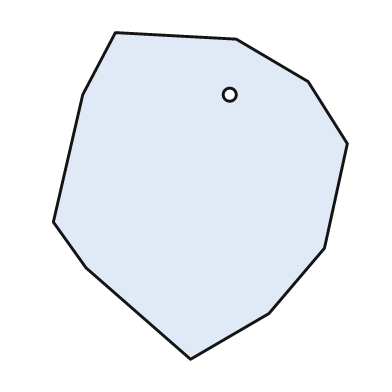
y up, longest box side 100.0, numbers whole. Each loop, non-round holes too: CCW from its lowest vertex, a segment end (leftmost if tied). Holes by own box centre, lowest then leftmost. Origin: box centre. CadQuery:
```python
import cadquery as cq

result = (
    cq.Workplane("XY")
    .moveTo(-3.0, -50.0)
    .lineTo(21.0, -36.0)
    .lineTo(38.0, -16.0)
    .lineTo(45.0, 16.0)
    .lineTo(33.0, 35.0)
    .lineTo(11.0, 48.0)
    .lineTo(-26.0, 50.0)
    .lineTo(-36.0, 31.0)
    .lineTo(-45.0, -8.0)
    .lineTo(-35.0, -22.0)
    .close()
    .moveTo(9.0, 31.0)
    .circle(2.0)
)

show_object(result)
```